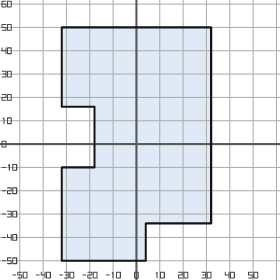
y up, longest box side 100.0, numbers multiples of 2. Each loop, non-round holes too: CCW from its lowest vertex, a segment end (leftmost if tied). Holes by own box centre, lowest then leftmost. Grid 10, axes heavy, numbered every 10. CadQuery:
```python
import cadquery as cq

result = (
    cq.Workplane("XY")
    .moveTo(-32.0, -50.0)
    .lineTo(4.0, -50.0)
    .lineTo(4.0, -34.0)
    .lineTo(32.0, -34.0)
    .lineTo(32.0, 50.0)
    .lineTo(-32.0, 50.0)
    .lineTo(-32.0, 16.0)
    .lineTo(-18.0, 16.0)
    .lineTo(-18.0, -10.0)
    .lineTo(-32.0, -10.0)
    .close()
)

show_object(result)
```